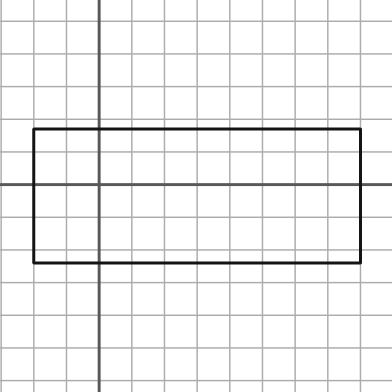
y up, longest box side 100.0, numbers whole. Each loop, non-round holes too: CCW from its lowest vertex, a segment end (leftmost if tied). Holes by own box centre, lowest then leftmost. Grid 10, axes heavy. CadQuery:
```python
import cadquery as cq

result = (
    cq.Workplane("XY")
    .moveTo(-20.0, -24.0)
    .lineTo(80.0, -24.0)
    .lineTo(80.0, 17.0)
    .lineTo(-20.0, 17.0)
    .close()
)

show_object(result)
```